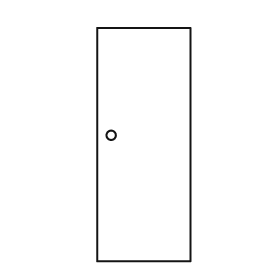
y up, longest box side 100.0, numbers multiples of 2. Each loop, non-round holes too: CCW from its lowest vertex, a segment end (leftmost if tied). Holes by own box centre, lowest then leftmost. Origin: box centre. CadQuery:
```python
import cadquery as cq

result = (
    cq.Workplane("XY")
    .moveTo(-20.0, -50.0)
    .lineTo(20.0, -50.0)
    .lineTo(20.0, 50.0)
    .lineTo(-20.0, 50.0)
    .close()
    .moveTo(-14.0, 4.0)
    .circle(2.0)
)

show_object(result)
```